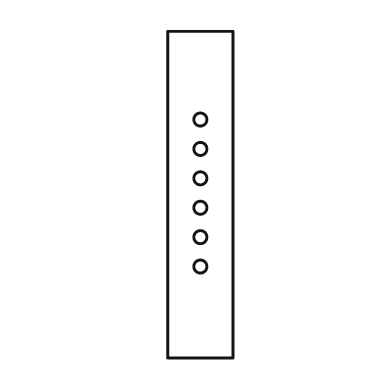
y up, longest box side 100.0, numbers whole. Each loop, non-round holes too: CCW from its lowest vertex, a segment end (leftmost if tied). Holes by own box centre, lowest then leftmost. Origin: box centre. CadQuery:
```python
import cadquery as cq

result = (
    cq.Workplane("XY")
    .moveTo(-10.0, -50.0)
    .lineTo(10.0, -50.0)
    .lineTo(10.0, 50.0)
    .lineTo(-10.0, 50.0)
    .close()
    .moveTo(0.0, -22.0)
    .circle(2.0)
    .moveTo(0.0, -13.0)
    .circle(2.0)
    .moveTo(0.0, -4.0)
    .circle(2.0)
    .moveTo(0.0, 5.0)
    .circle(2.0)
    .moveTo(0.0, 14.0)
    .circle(2.0)
    .moveTo(0.0, 23.0)
    .circle(2.0)
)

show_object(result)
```